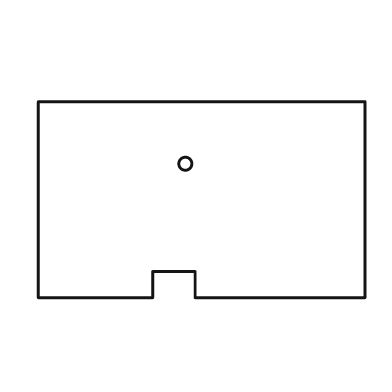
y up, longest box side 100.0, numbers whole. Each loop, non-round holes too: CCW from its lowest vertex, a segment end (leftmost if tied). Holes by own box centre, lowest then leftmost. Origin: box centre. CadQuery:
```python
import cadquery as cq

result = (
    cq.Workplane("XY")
    .moveTo(-50.0, -30.0)
    .lineTo(-15.0, -30.0)
    .lineTo(-15.0, -22.0)
    .lineTo(-2.0, -22.0)
    .lineTo(-2.0, -30.0)
    .lineTo(50.0, -30.0)
    .lineTo(50.0, 30.0)
    .lineTo(-50.0, 30.0)
    .close()
    .moveTo(-5.0, 11.0)
    .circle(2.0)
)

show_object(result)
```